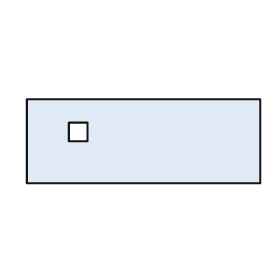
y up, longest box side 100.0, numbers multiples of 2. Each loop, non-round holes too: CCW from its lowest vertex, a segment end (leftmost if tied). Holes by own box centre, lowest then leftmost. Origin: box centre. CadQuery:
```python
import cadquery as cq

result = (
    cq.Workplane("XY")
    .moveTo(-50.0, -18.0)
    .lineTo(50.0, -18.0)
    .lineTo(50.0, 18.0)
    .lineTo(-50.0, 18.0)
    .close()
    .moveTo(-32.0, 0.0)
    .lineTo(-24.0, 0.0)
    .lineTo(-24.0, 8.0)
    .lineTo(-32.0, 8.0)
    .close()
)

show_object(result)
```